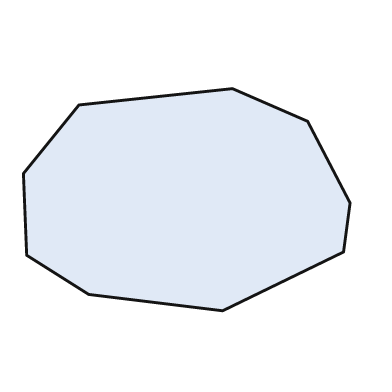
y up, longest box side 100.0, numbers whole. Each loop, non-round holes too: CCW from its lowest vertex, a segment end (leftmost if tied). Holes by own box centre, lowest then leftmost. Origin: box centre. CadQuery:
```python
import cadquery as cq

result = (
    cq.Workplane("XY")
    .moveTo(11.0, -34.0)
    .lineTo(48.0, -16.0)
    .lineTo(50.0, -1.0)
    .lineTo(37.0, 24.0)
    .lineTo(14.0, 34.0)
    .lineTo(-33.0, 29.0)
    .lineTo(-50.0, 8.0)
    .lineTo(-49.0, -17.0)
    .lineTo(-30.0, -29.0)
    .close()
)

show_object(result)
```